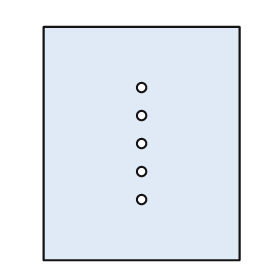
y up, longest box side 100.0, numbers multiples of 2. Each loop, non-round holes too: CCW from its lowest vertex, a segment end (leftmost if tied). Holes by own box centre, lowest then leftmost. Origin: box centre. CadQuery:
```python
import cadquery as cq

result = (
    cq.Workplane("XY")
    .moveTo(-42.0, -50.0)
    .lineTo(42.0, -50.0)
    .lineTo(42.0, 50.0)
    .lineTo(-42.0, 50.0)
    .close()
    .moveTo(0.0, -24.0)
    .circle(2.0)
    .moveTo(0.0, -12.0)
    .circle(2.0)
    .moveTo(0.0, 0.0)
    .circle(2.0)
    .moveTo(0.0, 12.0)
    .circle(2.0)
    .moveTo(0.0, 24.0)
    .circle(2.0)
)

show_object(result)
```